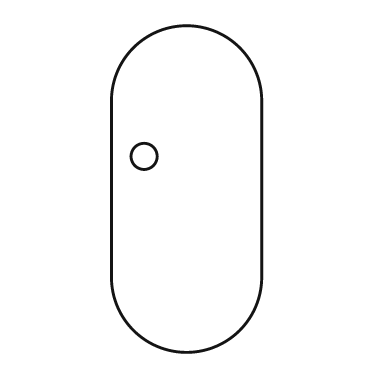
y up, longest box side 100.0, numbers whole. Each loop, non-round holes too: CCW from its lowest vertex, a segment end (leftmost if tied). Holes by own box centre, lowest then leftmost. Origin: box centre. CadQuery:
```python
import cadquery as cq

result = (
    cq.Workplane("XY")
    .moveTo(-23.0, -27.0)
    .threePointArc((0.0, -50.0), (23.0, -27.0))
    .lineTo(23.0, 27.0)
    .threePointArc((0.0, 50.0), (-23.0, 27.0))
    .close()
    .moveTo(-13.0, 10.0)
    .circle(4.0)
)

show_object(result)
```